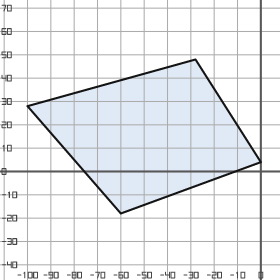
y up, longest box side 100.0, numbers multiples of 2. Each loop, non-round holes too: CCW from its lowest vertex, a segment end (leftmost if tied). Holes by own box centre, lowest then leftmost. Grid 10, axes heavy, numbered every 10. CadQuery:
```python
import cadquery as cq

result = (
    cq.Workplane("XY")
    .moveTo(-60.0, -18.0)
    .lineTo(0.0, 4.0)
    .lineTo(-28.0, 48.0)
    .lineTo(-100.0, 28.0)
    .close()
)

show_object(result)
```